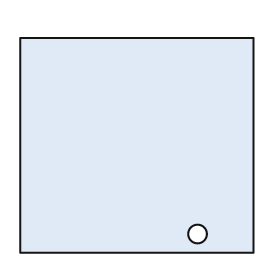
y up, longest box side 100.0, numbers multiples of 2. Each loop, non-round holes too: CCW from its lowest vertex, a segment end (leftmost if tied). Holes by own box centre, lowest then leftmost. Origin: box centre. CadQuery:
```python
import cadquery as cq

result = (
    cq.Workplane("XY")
    .moveTo(-50.0, -46.0)
    .lineTo(50.0, -46.0)
    .lineTo(50.0, 46.0)
    .lineTo(-50.0, 46.0)
    .close()
    .moveTo(26.0, -38.0)
    .circle(4.0)
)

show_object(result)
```